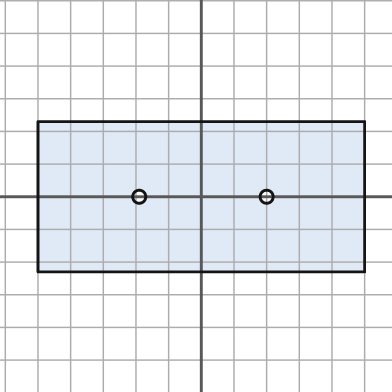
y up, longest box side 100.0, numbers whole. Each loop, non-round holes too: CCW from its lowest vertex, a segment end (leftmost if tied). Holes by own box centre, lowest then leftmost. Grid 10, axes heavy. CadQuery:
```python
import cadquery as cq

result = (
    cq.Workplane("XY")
    .moveTo(-50.0, -23.0)
    .lineTo(50.0, -23.0)
    .lineTo(50.0, 23.0)
    .lineTo(-50.0, 23.0)
    .close()
    .moveTo(-19.0, 0.0)
    .circle(2.0)
    .moveTo(20.0, 0.0)
    .circle(2.0)
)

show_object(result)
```